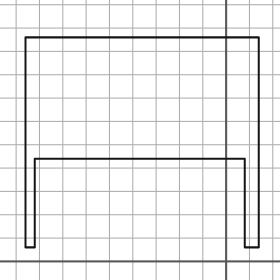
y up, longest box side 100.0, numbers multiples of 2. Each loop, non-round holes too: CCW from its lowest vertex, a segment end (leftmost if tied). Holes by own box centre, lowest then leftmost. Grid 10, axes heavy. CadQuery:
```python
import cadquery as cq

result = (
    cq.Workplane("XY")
    .moveTo(-86.0, 6.0)
    .lineTo(-82.0, 6.0)
    .lineTo(-82.0, 44.0)
    .lineTo(8.0, 44.0)
    .lineTo(8.0, 6.0)
    .lineTo(14.0, 6.0)
    .lineTo(14.0, 96.0)
    .lineTo(-86.0, 96.0)
    .close()
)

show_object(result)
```